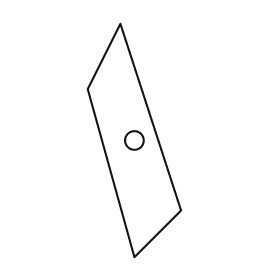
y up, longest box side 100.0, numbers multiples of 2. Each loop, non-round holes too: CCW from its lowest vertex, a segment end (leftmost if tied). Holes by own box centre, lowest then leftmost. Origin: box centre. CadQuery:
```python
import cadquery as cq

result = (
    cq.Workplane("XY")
    .moveTo(0.0, -50.0)
    .lineTo(20.0, -30.0)
    .lineTo(-6.0, 50.0)
    .lineTo(-20.0, 22.0)
    .close()
    .moveTo(0.0, 0.0)
    .circle(4.0)
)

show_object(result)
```